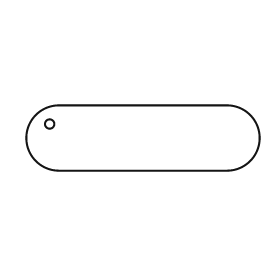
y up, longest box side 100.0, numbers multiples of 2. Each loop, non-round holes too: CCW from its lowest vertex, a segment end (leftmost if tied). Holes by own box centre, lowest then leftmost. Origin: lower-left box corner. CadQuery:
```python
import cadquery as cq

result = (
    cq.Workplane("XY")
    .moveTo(14.0, 0.0)
    .lineTo(86.0, 0.0)
    .threePointArc((100.0, 14.0), (86.0, 28.0))
    .lineTo(14.0, 28.0)
    .threePointArc((0.0, 14.0), (14.0, 0.0))
    .close()
    .moveTo(10.0, 20.0)
    .circle(2.0)
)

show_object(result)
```